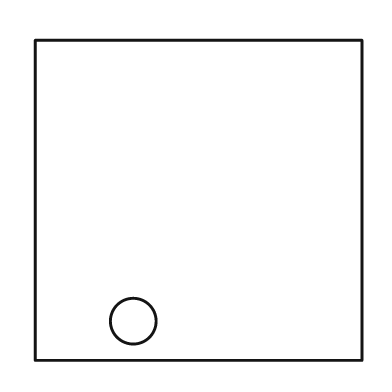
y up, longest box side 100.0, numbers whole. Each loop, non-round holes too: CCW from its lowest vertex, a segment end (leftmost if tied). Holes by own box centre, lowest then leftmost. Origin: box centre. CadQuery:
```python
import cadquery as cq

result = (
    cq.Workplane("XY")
    .moveTo(-50.0, -49.0)
    .lineTo(50.0, -49.0)
    .lineTo(50.0, 49.0)
    .lineTo(-50.0, 49.0)
    .close()
    .moveTo(-20.0, -37.0)
    .circle(7.0)
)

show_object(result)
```